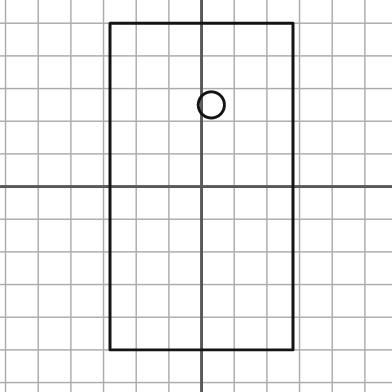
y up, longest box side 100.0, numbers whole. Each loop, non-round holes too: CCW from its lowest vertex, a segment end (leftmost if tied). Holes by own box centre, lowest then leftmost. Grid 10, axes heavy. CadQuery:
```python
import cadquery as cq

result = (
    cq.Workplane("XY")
    .moveTo(-28.0, -50.0)
    .lineTo(28.0, -50.0)
    .lineTo(28.0, 50.0)
    .lineTo(-28.0, 50.0)
    .close()
    .moveTo(3.0, 25.0)
    .circle(4.0)
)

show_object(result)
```